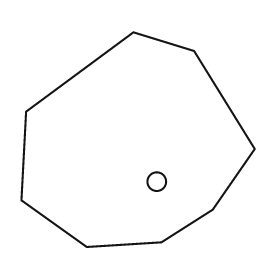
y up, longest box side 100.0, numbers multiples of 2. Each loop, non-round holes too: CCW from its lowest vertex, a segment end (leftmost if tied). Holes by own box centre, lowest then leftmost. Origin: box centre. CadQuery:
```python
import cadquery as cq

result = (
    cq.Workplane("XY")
    .moveTo(-22.0, -46.0)
    .lineTo(10.0, -44.0)
    .lineTo(32.0, -30.0)
    .lineTo(50.0, -4.0)
    .lineTo(24.0, 38.0)
    .lineTo(-2.0, 46.0)
    .lineTo(-48.0, 12.0)
    .lineTo(-50.0, -26.0)
    .close()
    .moveTo(8.0, -18.0)
    .circle(4.0)
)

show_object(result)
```